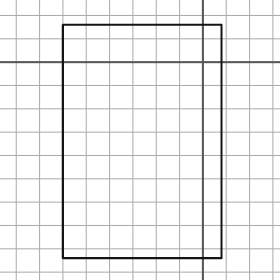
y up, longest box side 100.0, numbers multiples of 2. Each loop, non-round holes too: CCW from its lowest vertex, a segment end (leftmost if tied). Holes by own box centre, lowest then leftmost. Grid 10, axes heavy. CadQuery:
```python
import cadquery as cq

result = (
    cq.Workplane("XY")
    .moveTo(-60.0, -84.0)
    .lineTo(8.0, -84.0)
    .lineTo(8.0, 16.0)
    .lineTo(-60.0, 16.0)
    .close()
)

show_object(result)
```